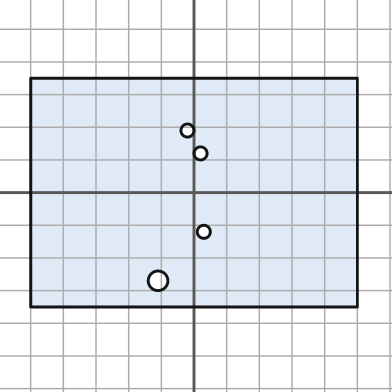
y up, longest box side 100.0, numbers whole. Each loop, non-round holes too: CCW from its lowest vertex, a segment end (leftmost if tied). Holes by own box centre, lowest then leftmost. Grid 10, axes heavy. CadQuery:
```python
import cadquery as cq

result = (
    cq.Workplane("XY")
    .moveTo(-50.0, -35.0)
    .lineTo(50.0, -35.0)
    .lineTo(50.0, 35.0)
    .lineTo(-50.0, 35.0)
    .close()
    .moveTo(-11.0, -27.0)
    .circle(3.0)
    .moveTo(3.0, -12.0)
    .circle(2.0)
    .moveTo(2.0, 12.0)
    .circle(2.0)
    .moveTo(-2.0, 19.0)
    .circle(2.0)
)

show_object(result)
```